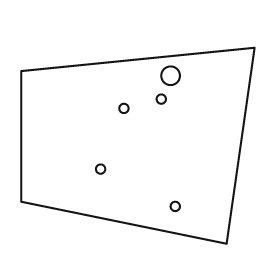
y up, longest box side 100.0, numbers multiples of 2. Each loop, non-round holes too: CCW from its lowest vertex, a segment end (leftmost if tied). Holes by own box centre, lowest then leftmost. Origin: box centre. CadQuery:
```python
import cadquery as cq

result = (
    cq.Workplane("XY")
    .moveTo(38.0, -42.0)
    .lineTo(50.0, 42.0)
    .lineTo(-50.0, 32.0)
    .lineTo(-50.0, -24.0)
    .close()
    .moveTo(16.0, -26.0)
    .circle(2.0)
    .moveTo(-16.0, -10.0)
    .circle(2.0)
    .moveTo(-6.0, 16.0)
    .circle(2.0)
    .moveTo(10.0, 20.0)
    .circle(2.0)
    .moveTo(14.0, 30.0)
    .circle(4.0)
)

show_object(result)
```